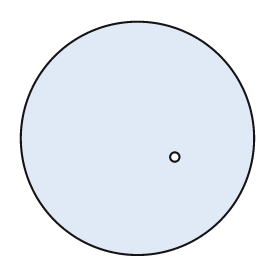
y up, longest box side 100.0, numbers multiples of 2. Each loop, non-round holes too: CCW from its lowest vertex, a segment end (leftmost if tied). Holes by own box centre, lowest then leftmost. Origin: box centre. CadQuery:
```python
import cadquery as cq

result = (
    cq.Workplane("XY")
    .moveTo(0.0, 0.0)
    .circle(50.0)
    .moveTo(16.0, -8.0)
    .circle(2.0)
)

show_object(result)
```